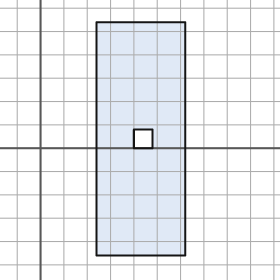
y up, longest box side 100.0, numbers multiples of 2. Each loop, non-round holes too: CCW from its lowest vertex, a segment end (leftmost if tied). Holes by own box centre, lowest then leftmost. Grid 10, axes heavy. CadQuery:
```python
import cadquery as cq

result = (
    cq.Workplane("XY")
    .moveTo(24.0, -46.0)
    .lineTo(62.0, -46.0)
    .lineTo(62.0, 54.0)
    .lineTo(24.0, 54.0)
    .close()
    .moveTo(40.0, 0.0)
    .lineTo(48.0, 0.0)
    .lineTo(48.0, 8.0)
    .lineTo(40.0, 8.0)
    .close()
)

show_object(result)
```